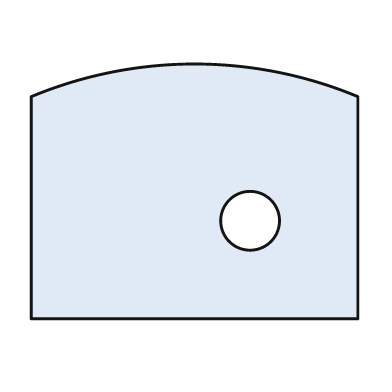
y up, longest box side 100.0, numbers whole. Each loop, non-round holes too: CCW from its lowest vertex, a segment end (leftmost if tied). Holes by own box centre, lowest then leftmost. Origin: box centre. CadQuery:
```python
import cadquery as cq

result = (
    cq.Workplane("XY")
    .moveTo(-50.0, -39.0)
    .lineTo(50.0, -39.0)
    .lineTo(50.0, 29.0)
    .threePointArc((0.0, 39.0), (-50.0, 29.0))
    .close()
    .moveTo(17.0, -9.0)
    .circle(9.0)
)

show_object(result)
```